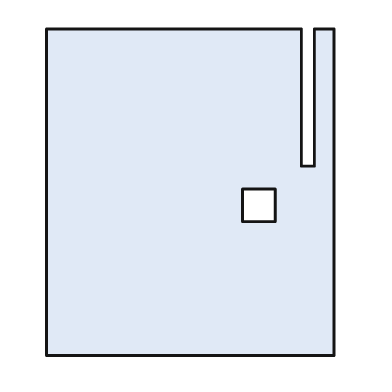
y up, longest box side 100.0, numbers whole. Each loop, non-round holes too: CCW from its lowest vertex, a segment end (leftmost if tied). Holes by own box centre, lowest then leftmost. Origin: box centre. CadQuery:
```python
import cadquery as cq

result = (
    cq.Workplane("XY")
    .moveTo(-44.0, -50.0)
    .lineTo(44.0, -50.0)
    .lineTo(44.0, 50.0)
    .lineTo(38.0, 50.0)
    .lineTo(38.0, 8.0)
    .lineTo(34.0, 8.0)
    .lineTo(34.0, 50.0)
    .lineTo(-44.0, 50.0)
    .close()
    .moveTo(16.0, -9.0)
    .lineTo(26.0, -9.0)
    .lineTo(26.0, 1.0)
    .lineTo(16.0, 1.0)
    .close()
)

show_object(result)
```